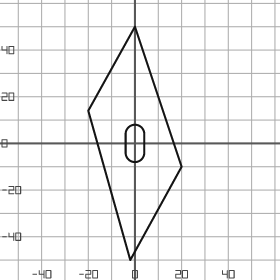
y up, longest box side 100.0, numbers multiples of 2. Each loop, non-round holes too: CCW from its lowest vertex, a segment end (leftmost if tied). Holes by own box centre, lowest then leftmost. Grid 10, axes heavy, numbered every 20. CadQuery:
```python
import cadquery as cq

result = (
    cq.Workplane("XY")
    .moveTo(-2.0, -50.0)
    .lineTo(20.0, -10.0)
    .lineTo(0.0, 50.0)
    .lineTo(-20.0, 14.0)
    .close()
    .moveTo(-4.0, -4.0)
    .threePointArc((0.0, -8.0), (4.0, -4.0))
    .lineTo(4.0, 4.0)
    .threePointArc((0.0, 8.0), (-4.0, 4.0))
    .close()
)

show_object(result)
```